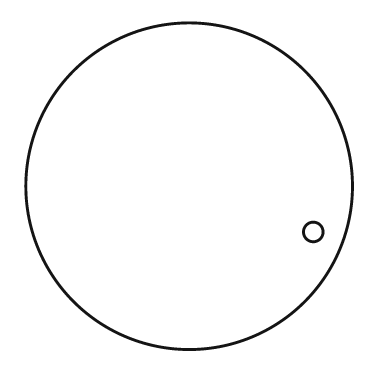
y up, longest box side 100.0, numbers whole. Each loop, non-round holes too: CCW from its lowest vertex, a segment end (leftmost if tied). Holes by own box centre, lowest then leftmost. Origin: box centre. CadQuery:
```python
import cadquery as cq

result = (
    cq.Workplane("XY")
    .moveTo(0.0, 0.0)
    .circle(50.0)
    .moveTo(38.0, -14.0)
    .circle(3.0)
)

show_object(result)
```